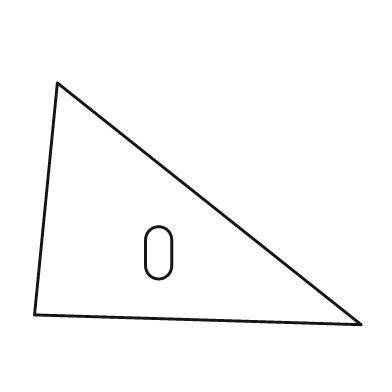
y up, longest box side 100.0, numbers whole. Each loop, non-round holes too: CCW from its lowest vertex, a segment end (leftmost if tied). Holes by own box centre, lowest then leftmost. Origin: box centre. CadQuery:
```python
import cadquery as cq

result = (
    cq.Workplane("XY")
    .moveTo(50.0, -37.0)
    .lineTo(-43.0, 37.0)
    .lineTo(-50.0, -34.0)
    .close()
    .moveTo(-16.0, -19.0)
    .threePointArc((-12.0, -23.0), (-8.0, -19.0))
    .lineTo(-8.0, -11.0)
    .threePointArc((-12.0, -7.0), (-16.0, -11.0))
    .close()
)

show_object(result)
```